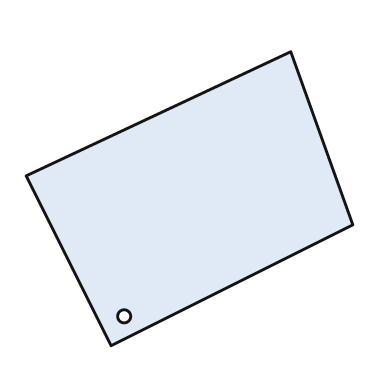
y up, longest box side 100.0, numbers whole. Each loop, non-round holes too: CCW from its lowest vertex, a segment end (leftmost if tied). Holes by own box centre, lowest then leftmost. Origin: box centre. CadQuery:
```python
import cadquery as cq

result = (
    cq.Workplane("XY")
    .moveTo(-24.0, -45.0)
    .lineTo(50.0, -8.0)
    .lineTo(31.0, 45.0)
    .lineTo(-50.0, 7.0)
    .close()
    .moveTo(-20.0, -36.0)
    .circle(2.0)
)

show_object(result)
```